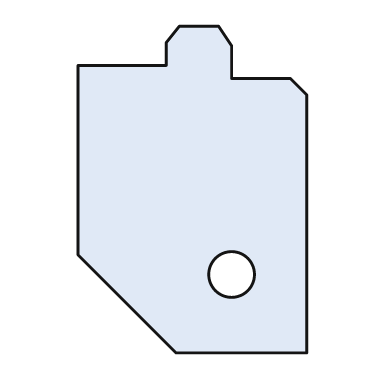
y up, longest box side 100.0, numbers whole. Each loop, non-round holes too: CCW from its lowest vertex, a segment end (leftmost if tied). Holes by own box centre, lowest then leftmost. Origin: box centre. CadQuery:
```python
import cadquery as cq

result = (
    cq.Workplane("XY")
    .moveTo(-5.0, -50.0)
    .lineTo(35.0, -50.0)
    .lineTo(35.0, 29.0)
    .lineTo(30.0, 34.0)
    .lineTo(12.0, 34.0)
    .lineTo(12.0, 44.0)
    .lineTo(8.0, 50.0)
    .lineTo(-4.0, 50.0)
    .lineTo(-8.0, 45.0)
    .lineTo(-8.0, 38.0)
    .lineTo(-35.0, 38.0)
    .lineTo(-35.0, -20.0)
    .close()
    .moveTo(12.0, -26.0)
    .circle(7.0)
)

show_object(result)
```